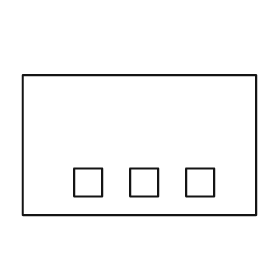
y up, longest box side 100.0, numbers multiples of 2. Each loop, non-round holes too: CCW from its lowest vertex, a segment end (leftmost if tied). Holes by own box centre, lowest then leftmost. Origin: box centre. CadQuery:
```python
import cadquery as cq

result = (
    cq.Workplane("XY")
    .moveTo(-50.0, -30.0)
    .lineTo(50.0, -30.0)
    .lineTo(50.0, 30.0)
    .lineTo(-50.0, 30.0)
    .close()
    .moveTo(-28.0, -22.0)
    .lineTo(-16.0, -22.0)
    .lineTo(-16.0, -10.0)
    .lineTo(-28.0, -10.0)
    .close()
    .moveTo(-4.0, -22.0)
    .lineTo(8.0, -22.0)
    .lineTo(8.0, -10.0)
    .lineTo(-4.0, -10.0)
    .close()
    .moveTo(20.0, -22.0)
    .lineTo(32.0, -22.0)
    .lineTo(32.0, -10.0)
    .lineTo(20.0, -10.0)
    .close()
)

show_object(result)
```